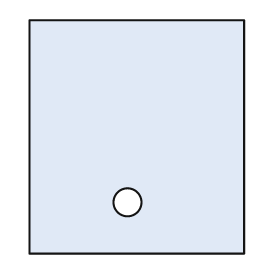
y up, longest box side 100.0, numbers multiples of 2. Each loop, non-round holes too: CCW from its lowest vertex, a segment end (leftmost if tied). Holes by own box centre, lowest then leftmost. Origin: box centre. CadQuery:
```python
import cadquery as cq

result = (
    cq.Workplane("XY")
    .moveTo(-46.0, -50.0)
    .lineTo(46.0, -50.0)
    .lineTo(46.0, 50.0)
    .lineTo(-46.0, 50.0)
    .close()
    .moveTo(-4.0, -28.0)
    .circle(6.0)
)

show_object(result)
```